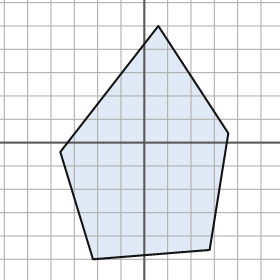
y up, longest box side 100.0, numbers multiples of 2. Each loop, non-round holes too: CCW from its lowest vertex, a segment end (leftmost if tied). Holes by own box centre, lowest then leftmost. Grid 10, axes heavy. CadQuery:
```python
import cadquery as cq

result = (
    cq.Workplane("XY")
    .moveTo(-22.0, -50.0)
    .lineTo(28.0, -46.0)
    .lineTo(36.0, 4.0)
    .lineTo(6.0, 50.0)
    .lineTo(-36.0, -4.0)
    .close()
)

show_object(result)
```